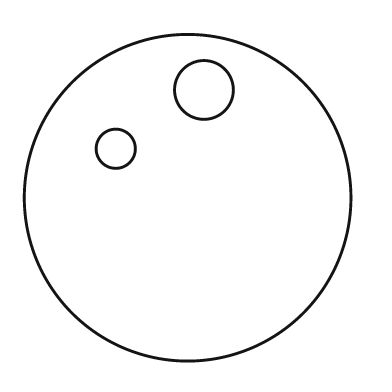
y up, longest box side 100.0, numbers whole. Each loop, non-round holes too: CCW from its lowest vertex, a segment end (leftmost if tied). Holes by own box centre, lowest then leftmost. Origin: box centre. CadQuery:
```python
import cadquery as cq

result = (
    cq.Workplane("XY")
    .moveTo(0.0, 0.0)
    .circle(50.0)
    .moveTo(-22.0, 15.0)
    .circle(6.0)
    .moveTo(5.0, 33.0)
    .circle(9.0)
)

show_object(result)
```